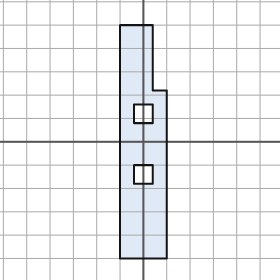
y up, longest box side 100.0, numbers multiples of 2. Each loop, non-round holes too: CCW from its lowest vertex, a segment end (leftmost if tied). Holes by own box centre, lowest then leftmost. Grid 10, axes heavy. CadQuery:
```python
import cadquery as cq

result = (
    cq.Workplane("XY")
    .moveTo(-10.0, -50.0)
    .lineTo(10.0, -50.0)
    .lineTo(10.0, 22.0)
    .lineTo(4.0, 22.0)
    .lineTo(4.0, 50.0)
    .lineTo(-10.0, 50.0)
    .close()
    .moveTo(-4.0, -18.0)
    .lineTo(4.0, -18.0)
    .lineTo(4.0, -10.0)
    .lineTo(-4.0, -10.0)
    .close()
    .moveTo(-4.0, 8.0)
    .lineTo(4.0, 8.0)
    .lineTo(4.0, 16.0)
    .lineTo(-4.0, 16.0)
    .close()
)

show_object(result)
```